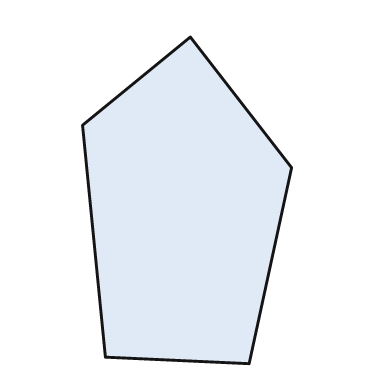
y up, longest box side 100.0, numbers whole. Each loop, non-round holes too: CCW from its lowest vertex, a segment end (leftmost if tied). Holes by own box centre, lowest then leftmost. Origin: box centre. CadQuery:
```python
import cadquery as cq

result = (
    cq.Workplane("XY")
    .moveTo(19.0, -50.0)
    .lineTo(32.0, 10.0)
    .lineTo(1.0, 50.0)
    .lineTo(-32.0, 23.0)
    .lineTo(-25.0, -48.0)
    .close()
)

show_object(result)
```